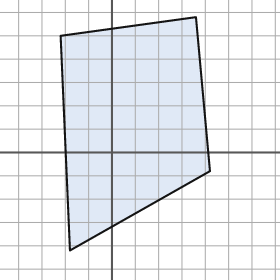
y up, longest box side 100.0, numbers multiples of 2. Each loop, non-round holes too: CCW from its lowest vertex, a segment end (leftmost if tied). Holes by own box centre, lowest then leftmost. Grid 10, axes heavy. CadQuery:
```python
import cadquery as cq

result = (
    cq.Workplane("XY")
    .moveTo(-18.0, -42.0)
    .lineTo(42.0, -8.0)
    .lineTo(36.0, 58.0)
    .lineTo(-22.0, 50.0)
    .close()
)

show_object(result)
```